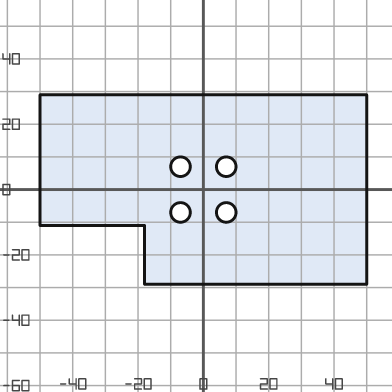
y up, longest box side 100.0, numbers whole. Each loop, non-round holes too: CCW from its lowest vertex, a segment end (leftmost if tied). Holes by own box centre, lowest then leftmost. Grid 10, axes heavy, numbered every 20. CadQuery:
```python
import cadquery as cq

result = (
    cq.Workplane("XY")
    .moveTo(-18.0, -29.0)
    .lineTo(50.0, -29.0)
    .lineTo(50.0, 29.0)
    .lineTo(-50.0, 29.0)
    .lineTo(-50.0, -11.0)
    .lineTo(-18.0, -11.0)
    .close()
    .moveTo(-7.0, -7.0)
    .circle(3.0)
    .moveTo(7.0, -7.0)
    .circle(3.0)
    .moveTo(-7.0, 7.0)
    .circle(3.0)
    .moveTo(7.0, 7.0)
    .circle(3.0)
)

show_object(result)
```